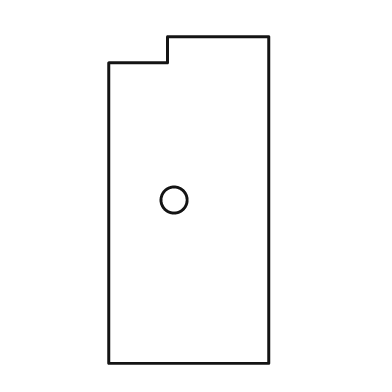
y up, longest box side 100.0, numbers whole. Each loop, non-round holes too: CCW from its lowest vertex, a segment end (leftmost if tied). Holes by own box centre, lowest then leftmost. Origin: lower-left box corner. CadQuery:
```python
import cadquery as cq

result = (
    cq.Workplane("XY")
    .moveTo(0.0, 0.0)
    .lineTo(49.0, 0.0)
    .lineTo(49.0, 100.0)
    .lineTo(18.0, 100.0)
    .lineTo(18.0, 92.0)
    .lineTo(0.0, 92.0)
    .close()
    .moveTo(20.0, 50.0)
    .circle(4.0)
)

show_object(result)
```